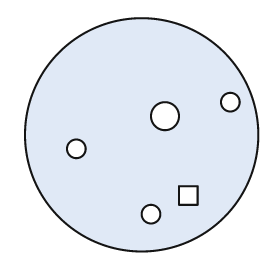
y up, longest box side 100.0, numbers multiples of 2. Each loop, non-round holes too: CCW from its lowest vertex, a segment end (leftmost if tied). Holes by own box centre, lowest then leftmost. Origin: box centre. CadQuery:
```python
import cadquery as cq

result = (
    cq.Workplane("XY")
    .moveTo(0.0, 0.0)
    .circle(50.0)
    .moveTo(4.0, -34.0)
    .circle(4.0)
    .moveTo(16.0, -30.0)
    .lineTo(24.0, -30.0)
    .lineTo(24.0, -22.0)
    .lineTo(16.0, -22.0)
    .close()
    .moveTo(-28.0, -6.0)
    .circle(4.0)
    .moveTo(10.0, 8.0)
    .circle(6.0)
    .moveTo(38.0, 14.0)
    .circle(4.0)
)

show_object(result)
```